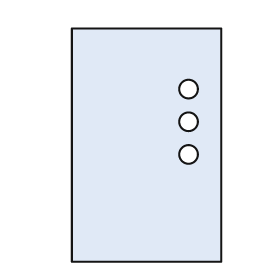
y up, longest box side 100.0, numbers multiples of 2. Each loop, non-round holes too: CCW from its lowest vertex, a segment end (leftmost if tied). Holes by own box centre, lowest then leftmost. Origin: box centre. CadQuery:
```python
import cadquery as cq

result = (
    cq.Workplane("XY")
    .moveTo(-32.0, -50.0)
    .lineTo(32.0, -50.0)
    .lineTo(32.0, 50.0)
    .lineTo(-32.0, 50.0)
    .close()
    .moveTo(18.0, -4.0)
    .circle(4.0)
    .moveTo(18.0, 10.0)
    .circle(4.0)
    .moveTo(18.0, 24.0)
    .circle(4.0)
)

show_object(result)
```